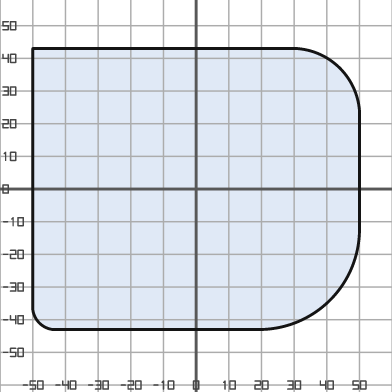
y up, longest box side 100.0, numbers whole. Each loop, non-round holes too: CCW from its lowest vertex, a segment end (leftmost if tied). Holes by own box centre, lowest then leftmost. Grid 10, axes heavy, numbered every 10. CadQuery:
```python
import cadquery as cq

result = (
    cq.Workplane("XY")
    .moveTo(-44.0, -43.0)
    .lineTo(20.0, -43.0)
    .threePointArc((41.0, -34.0), (50.0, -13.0))
    .lineTo(50.0, 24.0)
    .threePointArc((44.0, 37.0), (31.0, 43.0))
    .lineTo(-50.0, 43.0)
    .lineTo(-50.0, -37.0)
    .threePointArc((-48.0, -41.0), (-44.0, -43.0))
    .close()
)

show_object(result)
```